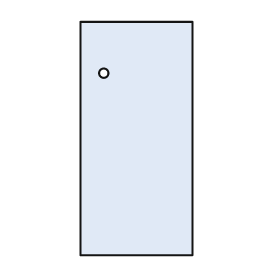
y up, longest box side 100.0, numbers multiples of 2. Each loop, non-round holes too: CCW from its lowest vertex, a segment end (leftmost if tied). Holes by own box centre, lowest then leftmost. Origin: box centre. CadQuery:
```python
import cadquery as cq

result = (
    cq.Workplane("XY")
    .moveTo(-24.0, -50.0)
    .lineTo(24.0, -50.0)
    .lineTo(24.0, 50.0)
    .lineTo(-24.0, 50.0)
    .close()
    .moveTo(-14.0, 28.0)
    .circle(2.0)
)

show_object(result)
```